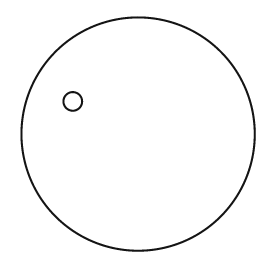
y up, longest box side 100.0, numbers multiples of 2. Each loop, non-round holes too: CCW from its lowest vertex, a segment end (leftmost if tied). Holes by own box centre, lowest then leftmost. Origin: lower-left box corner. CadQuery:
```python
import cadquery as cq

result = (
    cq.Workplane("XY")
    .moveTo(50.0, 50.0)
    .circle(50.0)
    .moveTo(22.0, 64.0)
    .circle(4.0)
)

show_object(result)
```